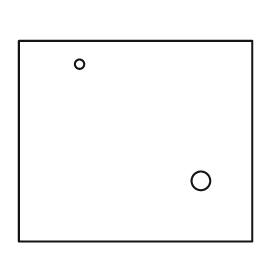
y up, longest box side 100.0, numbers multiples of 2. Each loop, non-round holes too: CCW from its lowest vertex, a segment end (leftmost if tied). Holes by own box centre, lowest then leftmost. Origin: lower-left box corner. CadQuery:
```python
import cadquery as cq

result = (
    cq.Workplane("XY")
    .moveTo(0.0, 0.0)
    .lineTo(100.0, 0.0)
    .lineTo(100.0, 86.0)
    .lineTo(0.0, 86.0)
    .close()
    .moveTo(78.0, 26.0)
    .circle(4.0)
    .moveTo(26.0, 76.0)
    .circle(2.0)
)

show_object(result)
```